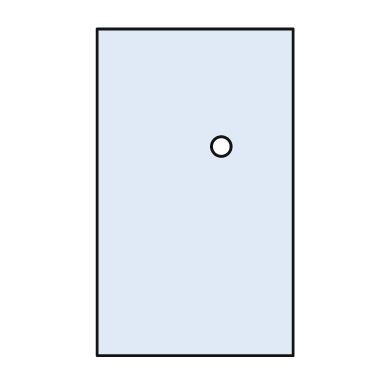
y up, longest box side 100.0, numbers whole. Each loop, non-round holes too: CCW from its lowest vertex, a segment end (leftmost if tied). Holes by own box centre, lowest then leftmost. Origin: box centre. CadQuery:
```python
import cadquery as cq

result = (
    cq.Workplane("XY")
    .moveTo(-30.0, -50.0)
    .lineTo(30.0, -50.0)
    .lineTo(30.0, 50.0)
    .lineTo(-30.0, 50.0)
    .close()
    .moveTo(8.0, 14.0)
    .circle(3.0)
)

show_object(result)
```